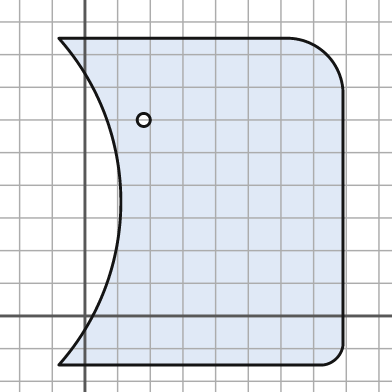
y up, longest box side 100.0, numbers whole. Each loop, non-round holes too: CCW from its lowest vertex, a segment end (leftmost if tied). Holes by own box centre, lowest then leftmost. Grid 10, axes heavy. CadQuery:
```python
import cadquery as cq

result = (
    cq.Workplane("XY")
    .moveTo(-8.0, -15.0)
    .lineTo(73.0, -15.0)
    .threePointArc((77.0, -13.0), (79.0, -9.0))
    .lineTo(79.0, 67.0)
    .threePointArc((74.0, 80.0), (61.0, 85.0))
    .lineTo(-8.0, 85.0)
    .threePointArc((11.0, 35.0), (-8.0, -15.0))
    .close()
    .moveTo(18.0, 60.0)
    .circle(2.0)
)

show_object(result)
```